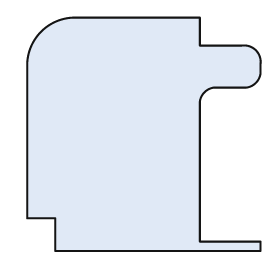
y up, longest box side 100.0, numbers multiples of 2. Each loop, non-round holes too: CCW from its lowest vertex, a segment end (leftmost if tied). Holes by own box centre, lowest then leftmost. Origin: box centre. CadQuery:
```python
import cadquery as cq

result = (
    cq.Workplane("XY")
    .moveTo(-38.0, -50.0)
    .lineTo(50.0, -50.0)
    .lineTo(50.0, -46.0)
    .lineTo(24.0, -46.0)
    .lineTo(24.0, 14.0)
    .threePointArc((26.0, 18.0), (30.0, 20.0))
    .lineTo(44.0, 20.0)
    .threePointArc((48.0, 22.0), (50.0, 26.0))
    .lineTo(50.0, 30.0)
    .threePointArc((48.0, 36.0), (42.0, 38.0))
    .lineTo(24.0, 38.0)
    .lineTo(24.0, 50.0)
    .lineTo(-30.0, 50.0)
    .threePointArc((-44.0, 44.0), (-50.0, 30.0))
    .lineTo(-50.0, -36.0)
    .lineTo(-38.0, -36.0)
    .close()
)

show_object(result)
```